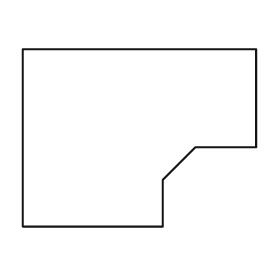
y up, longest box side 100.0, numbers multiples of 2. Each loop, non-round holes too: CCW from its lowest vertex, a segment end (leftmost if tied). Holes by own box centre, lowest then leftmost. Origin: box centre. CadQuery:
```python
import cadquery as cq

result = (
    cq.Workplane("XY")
    .moveTo(-50.0, -38.0)
    .lineTo(10.0, -38.0)
    .lineTo(10.0, -18.0)
    .lineTo(24.0, -4.0)
    .lineTo(50.0, -4.0)
    .lineTo(50.0, 38.0)
    .lineTo(-50.0, 38.0)
    .close()
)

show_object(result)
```